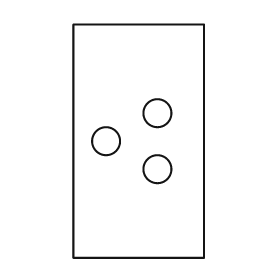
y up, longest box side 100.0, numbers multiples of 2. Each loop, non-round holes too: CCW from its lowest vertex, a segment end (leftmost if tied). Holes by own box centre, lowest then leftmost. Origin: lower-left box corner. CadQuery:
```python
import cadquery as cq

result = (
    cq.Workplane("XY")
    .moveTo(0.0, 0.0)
    .lineTo(56.0, 0.0)
    .lineTo(56.0, 100.0)
    .lineTo(0.0, 100.0)
    .close()
    .moveTo(36.0, 38.0)
    .circle(6.0)
    .moveTo(14.0, 50.0)
    .circle(6.0)
    .moveTo(36.0, 62.0)
    .circle(6.0)
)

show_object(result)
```